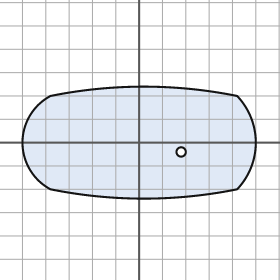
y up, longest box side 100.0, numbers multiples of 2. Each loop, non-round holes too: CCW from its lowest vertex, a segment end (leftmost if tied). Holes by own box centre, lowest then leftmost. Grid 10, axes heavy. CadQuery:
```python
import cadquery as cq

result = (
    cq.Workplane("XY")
    .moveTo(-38.0, -20.0)
    .threePointArc((2.0, -24.0), (42.0, -20.0))
    .threePointArc((50.0, 0.0), (42.0, 20.0))
    .threePointArc((2.0, 24.0), (-38.0, 20.0))
    .threePointArc((-50.0, 0.0), (-38.0, -20.0))
    .close()
    .moveTo(18.0, -4.0)
    .circle(2.0)
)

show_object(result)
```